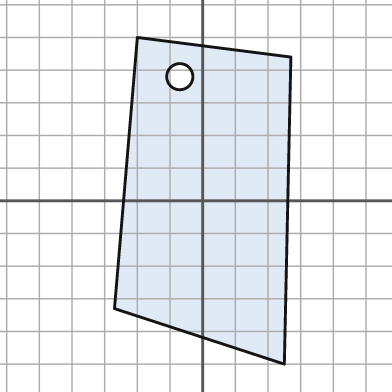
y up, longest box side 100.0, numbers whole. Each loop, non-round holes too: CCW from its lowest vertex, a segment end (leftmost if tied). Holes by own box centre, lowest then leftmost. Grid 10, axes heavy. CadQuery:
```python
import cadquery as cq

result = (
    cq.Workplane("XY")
    .moveTo(25.0, -50.0)
    .lineTo(27.0, 44.0)
    .lineTo(-20.0, 50.0)
    .lineTo(-27.0, -33.0)
    .close()
    .moveTo(-7.0, 38.0)
    .circle(4.0)
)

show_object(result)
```